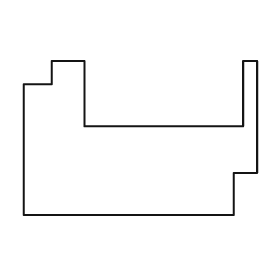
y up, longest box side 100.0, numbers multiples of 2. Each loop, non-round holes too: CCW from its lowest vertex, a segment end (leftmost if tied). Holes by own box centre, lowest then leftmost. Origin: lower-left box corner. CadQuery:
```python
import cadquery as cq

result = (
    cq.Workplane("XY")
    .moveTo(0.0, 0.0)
    .lineTo(90.0, 0.0)
    .lineTo(90.0, 18.0)
    .lineTo(100.0, 18.0)
    .lineTo(100.0, 66.0)
    .lineTo(94.0, 66.0)
    .lineTo(94.0, 38.0)
    .lineTo(26.0, 38.0)
    .lineTo(26.0, 66.0)
    .lineTo(12.0, 66.0)
    .lineTo(12.0, 56.0)
    .lineTo(0.0, 56.0)
    .close()
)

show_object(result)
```